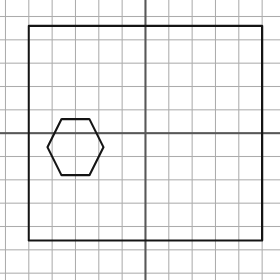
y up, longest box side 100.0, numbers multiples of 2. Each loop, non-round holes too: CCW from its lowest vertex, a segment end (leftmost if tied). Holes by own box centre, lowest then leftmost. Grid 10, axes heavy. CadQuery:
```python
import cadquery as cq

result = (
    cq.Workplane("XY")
    .moveTo(-50.0, -46.0)
    .lineTo(50.0, -46.0)
    .lineTo(50.0, 46.0)
    .lineTo(-50.0, 46.0)
    .close()
    .moveTo(-36.0, -18.0)
    .lineTo(-24.0, -18.0)
    .lineTo(-18.0, -6.0)
    .lineTo(-24.0, 6.0)
    .lineTo(-36.0, 6.0)
    .lineTo(-42.0, -6.0)
    .close()
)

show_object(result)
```